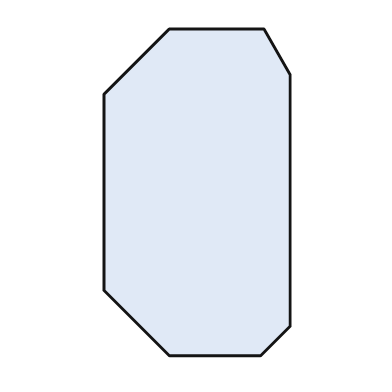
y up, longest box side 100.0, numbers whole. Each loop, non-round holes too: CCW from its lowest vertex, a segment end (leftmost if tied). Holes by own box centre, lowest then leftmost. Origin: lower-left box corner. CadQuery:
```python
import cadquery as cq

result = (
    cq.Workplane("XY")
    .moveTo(20.0, 0.0)
    .lineTo(48.0, 0.0)
    .lineTo(57.0, 9.0)
    .lineTo(57.0, 86.0)
    .lineTo(49.0, 100.0)
    .lineTo(20.0, 100.0)
    .lineTo(0.0, 80.0)
    .lineTo(0.0, 20.0)
    .close()
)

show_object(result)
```